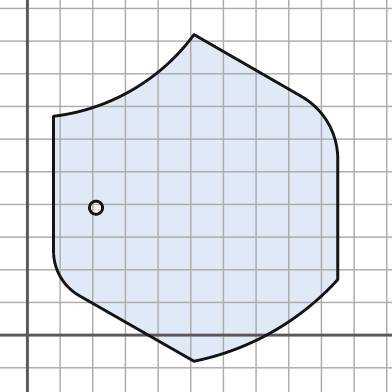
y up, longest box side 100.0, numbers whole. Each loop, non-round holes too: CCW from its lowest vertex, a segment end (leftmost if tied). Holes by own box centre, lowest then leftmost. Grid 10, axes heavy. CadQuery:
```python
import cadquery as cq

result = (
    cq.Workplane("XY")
    .moveTo(51.0, -8.0)
    .threePointArc((75.0, 1.0), (95.0, 17.0))
    .lineTo(95.0, 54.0)
    .threePointArc((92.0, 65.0), (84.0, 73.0))
    .lineTo(51.0, 92.0)
    .threePointArc((32.0, 75.0), (8.0, 67.0))
    .lineTo(8.0, 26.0)
    .threePointArc((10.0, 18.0), (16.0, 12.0))
    .close()
    .moveTo(21.0, 39.0)
    .circle(2.0)
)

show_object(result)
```